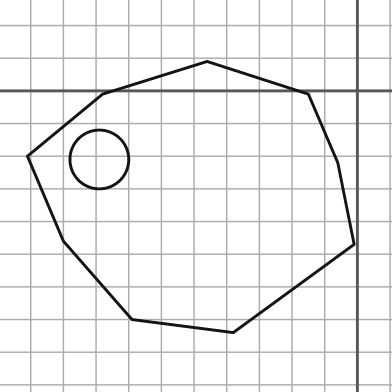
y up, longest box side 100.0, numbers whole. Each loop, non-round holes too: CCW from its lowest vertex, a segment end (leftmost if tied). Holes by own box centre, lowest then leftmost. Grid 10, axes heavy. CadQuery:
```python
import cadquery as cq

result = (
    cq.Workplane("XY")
    .moveTo(-38.0, -74.0)
    .lineTo(-1.0, -47.0)
    .lineTo(-6.0, -22.0)
    .lineTo(-15.0, -1.0)
    .lineTo(-46.0, 9.0)
    .lineTo(-78.0, -1.0)
    .lineTo(-101.0, -20.0)
    .lineTo(-90.0, -46.0)
    .lineTo(-69.0, -70.0)
    .close()
    .moveTo(-79.0, -21.0)
    .circle(9.0)
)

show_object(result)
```